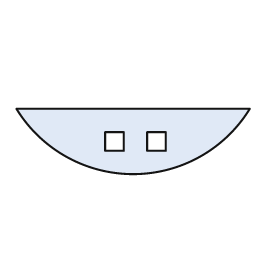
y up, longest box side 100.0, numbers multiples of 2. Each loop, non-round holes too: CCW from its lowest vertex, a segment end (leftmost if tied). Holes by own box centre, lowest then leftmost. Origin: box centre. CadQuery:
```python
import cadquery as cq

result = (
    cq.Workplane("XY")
    .moveTo(-50.0, 14.0)
    .threePointArc((0.0, -14.0), (50.0, 14.0))
    .close()
    .moveTo(-12.0, -4.0)
    .lineTo(-4.0, -4.0)
    .lineTo(-4.0, 4.0)
    .lineTo(-12.0, 4.0)
    .close()
    .moveTo(6.0, -4.0)
    .lineTo(14.0, -4.0)
    .lineTo(14.0, 4.0)
    .lineTo(6.0, 4.0)
    .close()
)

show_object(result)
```